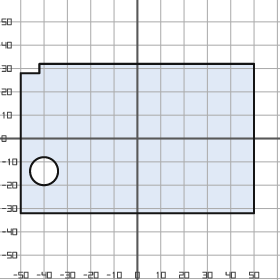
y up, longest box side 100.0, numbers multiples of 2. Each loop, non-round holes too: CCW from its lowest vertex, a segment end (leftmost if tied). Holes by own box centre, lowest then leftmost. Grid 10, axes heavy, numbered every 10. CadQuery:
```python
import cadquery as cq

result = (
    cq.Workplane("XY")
    .moveTo(-50.0, -32.0)
    .lineTo(50.0, -32.0)
    .lineTo(50.0, 32.0)
    .lineTo(-42.0, 32.0)
    .lineTo(-42.0, 28.0)
    .lineTo(-50.0, 28.0)
    .close()
    .moveTo(-40.0, -14.0)
    .circle(6.0)
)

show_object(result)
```